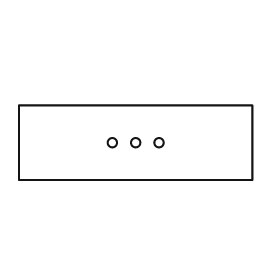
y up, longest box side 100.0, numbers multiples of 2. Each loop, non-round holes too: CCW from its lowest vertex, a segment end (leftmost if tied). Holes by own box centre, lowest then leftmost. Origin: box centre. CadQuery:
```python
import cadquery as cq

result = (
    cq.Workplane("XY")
    .moveTo(-50.0, -16.0)
    .lineTo(50.0, -16.0)
    .lineTo(50.0, 16.0)
    .lineTo(-50.0, 16.0)
    .close()
    .moveTo(-10.0, 0.0)
    .circle(2.0)
    .moveTo(0.0, 0.0)
    .circle(2.0)
    .moveTo(10.0, 0.0)
    .circle(2.0)
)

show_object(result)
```